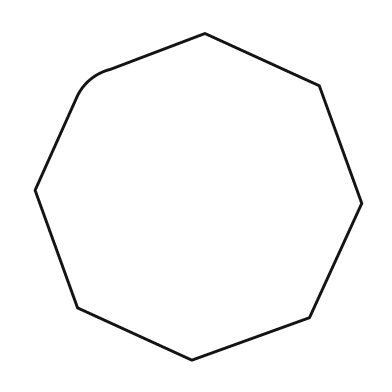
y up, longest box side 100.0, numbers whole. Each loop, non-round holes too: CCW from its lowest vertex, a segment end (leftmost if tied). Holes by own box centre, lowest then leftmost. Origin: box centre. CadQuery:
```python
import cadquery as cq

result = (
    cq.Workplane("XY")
    .moveTo(-2.0, -50.0)
    .lineTo(34.0, -37.0)
    .lineTo(50.0, -2.0)
    .lineTo(37.0, 34.0)
    .lineTo(2.0, 50.0)
    .lineTo(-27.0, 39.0)
    .threePointArc((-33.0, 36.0), (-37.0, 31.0))
    .lineTo(-50.0, 2.0)
    .lineTo(-37.0, -34.0)
    .close()
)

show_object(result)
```